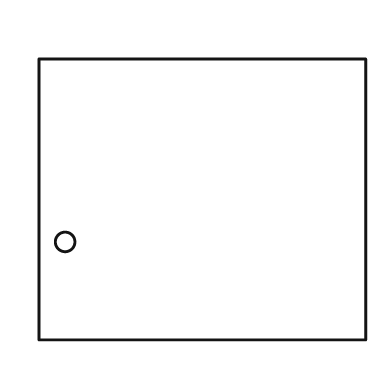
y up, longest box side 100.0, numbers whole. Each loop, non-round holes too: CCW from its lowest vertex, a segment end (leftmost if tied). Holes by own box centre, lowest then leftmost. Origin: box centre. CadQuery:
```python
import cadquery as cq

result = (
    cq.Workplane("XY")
    .moveTo(-50.0, -43.0)
    .lineTo(50.0, -43.0)
    .lineTo(50.0, 43.0)
    .lineTo(-50.0, 43.0)
    .close()
    .moveTo(-42.0, -13.0)
    .circle(3.0)
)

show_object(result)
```